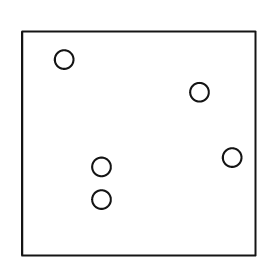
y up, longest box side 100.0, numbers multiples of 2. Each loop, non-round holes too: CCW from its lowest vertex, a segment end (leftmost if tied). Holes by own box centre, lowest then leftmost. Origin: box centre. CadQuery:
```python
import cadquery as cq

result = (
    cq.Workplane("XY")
    .moveTo(-50.0, -48.0)
    .lineTo(50.0, -48.0)
    .lineTo(50.0, 48.0)
    .lineTo(-50.0, 48.0)
    .close()
    .moveTo(-16.0, -24.0)
    .circle(4.0)
    .moveTo(-16.0, -10.0)
    .circle(4.0)
    .moveTo(40.0, -6.0)
    .circle(4.0)
    .moveTo(26.0, 22.0)
    .circle(4.0)
    .moveTo(-32.0, 36.0)
    .circle(4.0)
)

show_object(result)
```